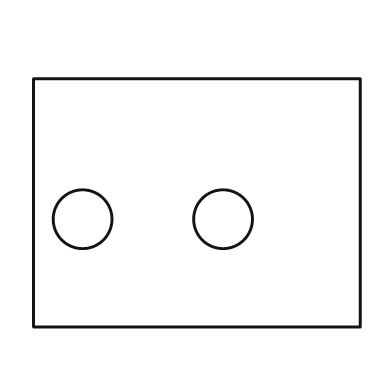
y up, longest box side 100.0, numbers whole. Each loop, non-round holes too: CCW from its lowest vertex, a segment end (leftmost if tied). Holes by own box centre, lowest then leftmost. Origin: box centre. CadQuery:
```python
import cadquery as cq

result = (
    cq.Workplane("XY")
    .moveTo(-50.0, -38.0)
    .lineTo(50.0, -38.0)
    .lineTo(50.0, 38.0)
    .lineTo(-50.0, 38.0)
    .close()
    .moveTo(-35.0, -5.0)
    .circle(9.0)
    .moveTo(8.0, -5.0)
    .circle(9.0)
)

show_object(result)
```